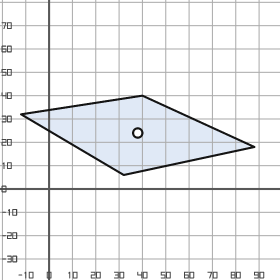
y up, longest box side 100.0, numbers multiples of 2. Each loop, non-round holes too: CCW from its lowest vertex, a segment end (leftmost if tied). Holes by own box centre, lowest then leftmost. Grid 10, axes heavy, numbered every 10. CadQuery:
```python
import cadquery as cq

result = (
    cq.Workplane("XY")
    .moveTo(32.0, 6.0)
    .lineTo(88.0, 18.0)
    .lineTo(40.0, 40.0)
    .lineTo(-12.0, 32.0)
    .close()
    .moveTo(38.0, 24.0)
    .circle(2.0)
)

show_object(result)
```